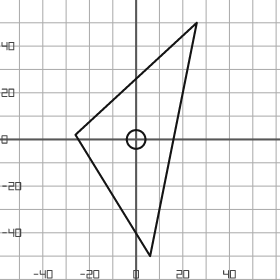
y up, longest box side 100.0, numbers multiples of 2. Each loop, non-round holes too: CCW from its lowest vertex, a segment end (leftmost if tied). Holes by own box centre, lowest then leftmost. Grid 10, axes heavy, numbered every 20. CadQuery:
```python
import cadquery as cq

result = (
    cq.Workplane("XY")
    .moveTo(6.0, -50.0)
    .lineTo(26.0, 50.0)
    .lineTo(-26.0, 2.0)
    .close()
    .moveTo(0.0, 0.0)
    .circle(4.0)
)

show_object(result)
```